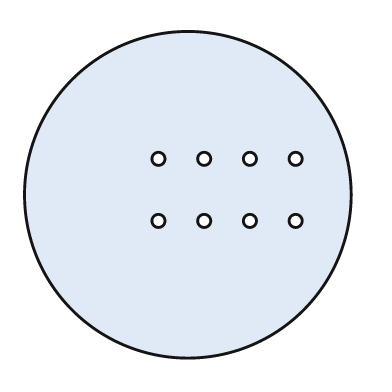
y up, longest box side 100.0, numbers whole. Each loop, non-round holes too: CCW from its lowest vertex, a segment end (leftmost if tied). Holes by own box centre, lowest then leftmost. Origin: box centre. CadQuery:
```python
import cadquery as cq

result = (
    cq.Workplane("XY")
    .moveTo(0.0, 0.0)
    .circle(50.0)
    .moveTo(-9.0, -8.0)
    .circle(2.0)
    .moveTo(5.0, -8.0)
    .circle(2.0)
    .moveTo(19.0, -8.0)
    .circle(2.0)
    .moveTo(33.0, -8.0)
    .circle(2.0)
    .moveTo(-9.0, 11.0)
    .circle(2.0)
    .moveTo(5.0, 11.0)
    .circle(2.0)
    .moveTo(19.0, 11.0)
    .circle(2.0)
    .moveTo(33.0, 11.0)
    .circle(2.0)
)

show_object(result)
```